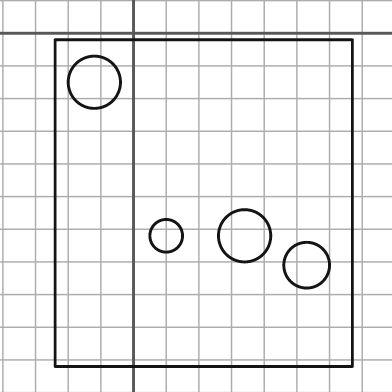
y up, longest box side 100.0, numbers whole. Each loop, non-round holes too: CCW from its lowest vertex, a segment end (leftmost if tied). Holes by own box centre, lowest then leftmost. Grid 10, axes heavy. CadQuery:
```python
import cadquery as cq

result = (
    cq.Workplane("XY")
    .moveTo(-24.0, -102.0)
    .lineTo(67.0, -102.0)
    .lineTo(67.0, -2.0)
    .lineTo(-24.0, -2.0)
    .close()
    .moveTo(53.0, -71.0)
    .circle(7.0)
    .moveTo(10.0, -62.0)
    .circle(5.0)
    .moveTo(34.0, -62.0)
    .circle(8.0)
    .moveTo(-12.0, -15.0)
    .circle(8.0)
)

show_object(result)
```